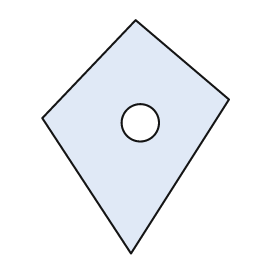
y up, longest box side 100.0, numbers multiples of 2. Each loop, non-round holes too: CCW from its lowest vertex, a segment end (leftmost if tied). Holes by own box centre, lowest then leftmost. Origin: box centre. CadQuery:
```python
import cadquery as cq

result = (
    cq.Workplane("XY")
    .moveTo(-2.0, -50.0)
    .lineTo(40.0, 16.0)
    .lineTo(0.0, 50.0)
    .lineTo(-40.0, 8.0)
    .close()
    .moveTo(2.0, 6.0)
    .circle(8.0)
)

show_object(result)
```